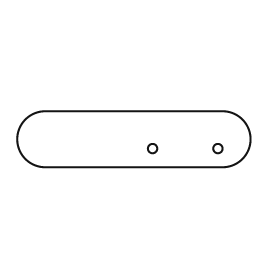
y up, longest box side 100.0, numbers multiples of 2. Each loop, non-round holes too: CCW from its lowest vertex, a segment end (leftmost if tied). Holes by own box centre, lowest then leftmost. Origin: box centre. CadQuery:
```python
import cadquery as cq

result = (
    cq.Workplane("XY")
    .moveTo(-38.0, -12.0)
    .lineTo(38.0, -12.0)
    .threePointArc((50.0, 0.0), (38.0, 12.0))
    .lineTo(-38.0, 12.0)
    .threePointArc((-50.0, 0.0), (-38.0, -12.0))
    .close()
    .moveTo(8.0, -4.0)
    .circle(2.0)
    .moveTo(36.0, -4.0)
    .circle(2.0)
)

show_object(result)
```